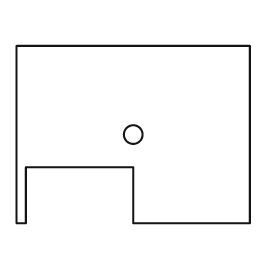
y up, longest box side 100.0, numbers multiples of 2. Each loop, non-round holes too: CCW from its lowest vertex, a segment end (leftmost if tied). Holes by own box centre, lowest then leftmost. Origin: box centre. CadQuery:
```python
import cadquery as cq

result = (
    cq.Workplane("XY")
    .moveTo(-50.0, -38.0)
    .lineTo(-46.0, -38.0)
    .lineTo(-46.0, -14.0)
    .lineTo(0.0, -14.0)
    .lineTo(0.0, -38.0)
    .lineTo(50.0, -38.0)
    .lineTo(50.0, 38.0)
    .lineTo(-50.0, 38.0)
    .close()
    .moveTo(0.0, 0.0)
    .circle(4.0)
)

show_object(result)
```